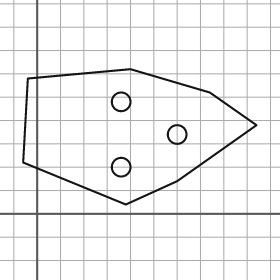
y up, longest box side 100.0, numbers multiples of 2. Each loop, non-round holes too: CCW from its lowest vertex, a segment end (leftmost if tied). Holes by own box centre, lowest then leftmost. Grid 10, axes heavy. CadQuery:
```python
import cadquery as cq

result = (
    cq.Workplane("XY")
    .moveTo(38.0, 4.0)
    .lineTo(60.0, 14.0)
    .lineTo(94.0, 38.0)
    .lineTo(74.0, 52.0)
    .lineTo(40.0, 62.0)
    .lineTo(-4.0, 58.0)
    .lineTo(-6.0, 22.0)
    .close()
    .moveTo(36.0, 20.0)
    .circle(4.0)
    .moveTo(60.0, 34.0)
    .circle(4.0)
    .moveTo(36.0, 48.0)
    .circle(4.0)
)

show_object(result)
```